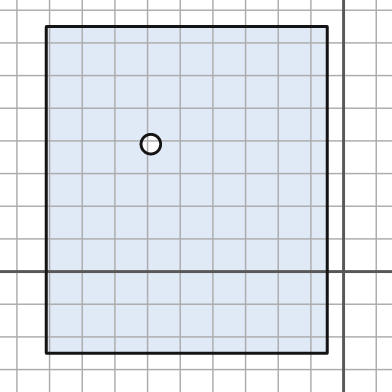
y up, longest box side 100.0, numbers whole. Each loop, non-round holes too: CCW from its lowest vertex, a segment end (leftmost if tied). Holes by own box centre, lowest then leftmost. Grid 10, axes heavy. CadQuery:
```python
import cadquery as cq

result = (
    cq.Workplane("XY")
    .moveTo(-91.0, -25.0)
    .lineTo(-5.0, -25.0)
    .lineTo(-5.0, 75.0)
    .lineTo(-91.0, 75.0)
    .close()
    .moveTo(-59.0, 39.0)
    .circle(3.0)
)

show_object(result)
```